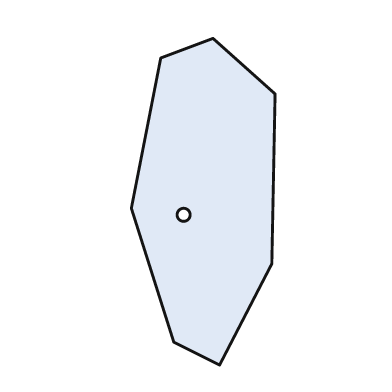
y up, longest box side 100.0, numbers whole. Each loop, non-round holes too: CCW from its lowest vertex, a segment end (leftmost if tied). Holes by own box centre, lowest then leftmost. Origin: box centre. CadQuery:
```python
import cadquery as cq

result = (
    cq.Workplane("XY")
    .moveTo(5.0, -50.0)
    .lineTo(21.0, -19.0)
    .lineTo(22.0, 33.0)
    .lineTo(3.0, 50.0)
    .lineTo(-13.0, 44.0)
    .lineTo(-22.0, -2.0)
    .lineTo(-9.0, -43.0)
    .close()
    .moveTo(-6.0, -4.0)
    .circle(2.0)
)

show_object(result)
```